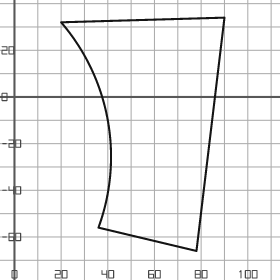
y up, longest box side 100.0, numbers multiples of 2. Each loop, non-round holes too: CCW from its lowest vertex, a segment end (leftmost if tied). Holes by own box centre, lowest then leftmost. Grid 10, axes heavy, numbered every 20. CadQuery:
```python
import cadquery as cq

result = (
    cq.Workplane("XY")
    .moveTo(78.0, -66.0)
    .lineTo(90.0, 34.0)
    .lineTo(20.0, 32.0)
    .threePointArc((40.0, -10.0), (36.0, -56.0))
    .close()
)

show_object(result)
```